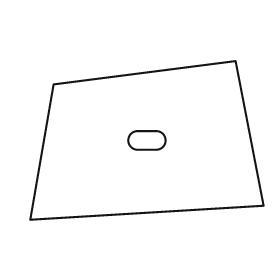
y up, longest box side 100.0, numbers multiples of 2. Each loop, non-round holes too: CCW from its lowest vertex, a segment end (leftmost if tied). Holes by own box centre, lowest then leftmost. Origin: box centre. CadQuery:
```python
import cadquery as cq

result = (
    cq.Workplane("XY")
    .moveTo(-50.0, -34.0)
    .lineTo(50.0, -28.0)
    .lineTo(38.0, 34.0)
    .lineTo(-40.0, 24.0)
    .close()
    .moveTo(-4.0, -4.0)
    .lineTo(4.0, -4.0)
    .threePointArc((8.0, 0.0), (4.0, 4.0))
    .lineTo(-4.0, 4.0)
    .threePointArc((-8.0, 0.0), (-4.0, -4.0))
    .close()
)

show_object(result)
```